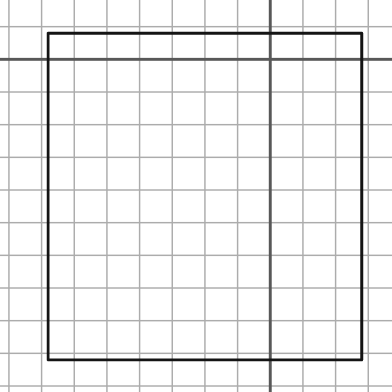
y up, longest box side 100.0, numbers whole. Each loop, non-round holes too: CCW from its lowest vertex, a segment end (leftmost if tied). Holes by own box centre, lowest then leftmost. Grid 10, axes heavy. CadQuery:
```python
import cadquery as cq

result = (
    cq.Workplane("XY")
    .moveTo(-68.0, -92.0)
    .lineTo(28.0, -92.0)
    .lineTo(28.0, 8.0)
    .lineTo(-68.0, 8.0)
    .close()
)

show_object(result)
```